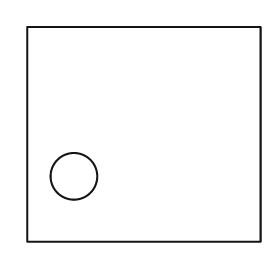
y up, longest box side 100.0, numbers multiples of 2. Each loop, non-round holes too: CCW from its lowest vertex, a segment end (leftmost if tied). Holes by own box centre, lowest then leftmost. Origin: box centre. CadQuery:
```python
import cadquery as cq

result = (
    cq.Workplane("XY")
    .moveTo(-50.0, -46.0)
    .lineTo(50.0, -46.0)
    .lineTo(50.0, 46.0)
    .lineTo(-50.0, 46.0)
    .close()
    .moveTo(-30.0, -18.0)
    .circle(10.0)
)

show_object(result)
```